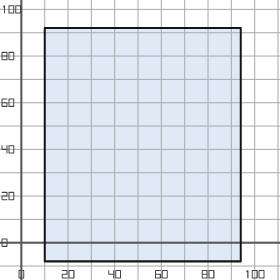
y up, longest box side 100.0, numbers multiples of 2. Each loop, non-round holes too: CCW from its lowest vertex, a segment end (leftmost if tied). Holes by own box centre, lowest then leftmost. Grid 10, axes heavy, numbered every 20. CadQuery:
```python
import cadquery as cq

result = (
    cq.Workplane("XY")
    .moveTo(10.0, -8.0)
    .lineTo(94.0, -8.0)
    .lineTo(94.0, 92.0)
    .lineTo(10.0, 92.0)
    .close()
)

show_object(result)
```